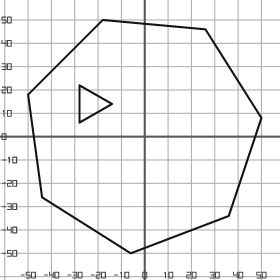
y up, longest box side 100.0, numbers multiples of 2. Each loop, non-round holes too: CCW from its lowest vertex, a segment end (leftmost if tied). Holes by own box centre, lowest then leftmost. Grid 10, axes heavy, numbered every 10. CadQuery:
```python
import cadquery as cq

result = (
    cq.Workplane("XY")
    .moveTo(-6.0, -50.0)
    .lineTo(36.0, -34.0)
    .lineTo(50.0, 8.0)
    .lineTo(26.0, 46.0)
    .lineTo(-18.0, 50.0)
    .lineTo(-50.0, 18.0)
    .lineTo(-44.0, -26.0)
    .close()
    .moveTo(-28.0, 6.0)
    .lineTo(-14.0, 14.0)
    .lineTo(-28.0, 22.0)
    .close()
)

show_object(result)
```